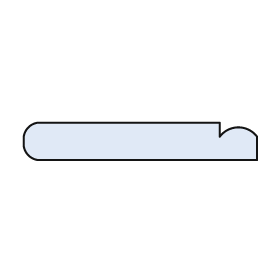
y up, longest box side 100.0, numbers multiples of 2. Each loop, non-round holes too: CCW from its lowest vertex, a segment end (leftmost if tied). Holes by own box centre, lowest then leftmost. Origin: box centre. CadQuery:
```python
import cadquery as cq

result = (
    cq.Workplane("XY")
    .moveTo(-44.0, -8.0)
    .lineTo(50.0, -8.0)
    .lineTo(50.0, 2.0)
    .threePointArc((42.0, 6.0), (34.0, 2.0))
    .lineTo(34.0, 8.0)
    .lineTo(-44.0, 8.0)
    .threePointArc((-48.0, 6.0), (-50.0, 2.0))
    .lineTo(-50.0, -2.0)
    .threePointArc((-48.0, -6.0), (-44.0, -8.0))
    .close()
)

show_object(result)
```